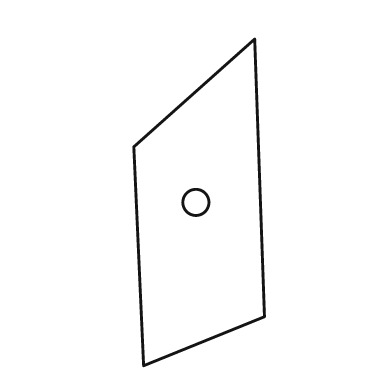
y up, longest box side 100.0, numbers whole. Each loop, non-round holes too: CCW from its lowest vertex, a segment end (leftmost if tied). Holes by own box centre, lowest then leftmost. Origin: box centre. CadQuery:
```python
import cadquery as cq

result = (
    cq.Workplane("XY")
    .moveTo(-17.0, -50.0)
    .lineTo(20.0, -35.0)
    .lineTo(17.0, 50.0)
    .lineTo(-20.0, 17.0)
    .close()
    .moveTo(-1.0, 0.0)
    .circle(4.0)
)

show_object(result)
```